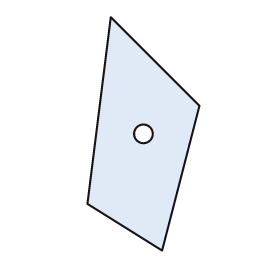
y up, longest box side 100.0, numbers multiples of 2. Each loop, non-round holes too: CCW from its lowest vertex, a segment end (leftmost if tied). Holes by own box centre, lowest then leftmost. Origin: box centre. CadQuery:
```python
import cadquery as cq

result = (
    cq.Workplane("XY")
    .moveTo(8.0, -50.0)
    .lineTo(24.0, 12.0)
    .lineTo(-14.0, 50.0)
    .lineTo(-24.0, -30.0)
    .close()
    .moveTo(0.0, 0.0)
    .circle(4.0)
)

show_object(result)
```